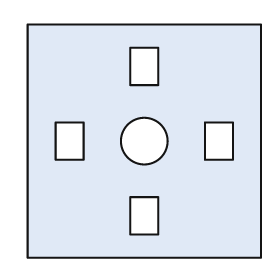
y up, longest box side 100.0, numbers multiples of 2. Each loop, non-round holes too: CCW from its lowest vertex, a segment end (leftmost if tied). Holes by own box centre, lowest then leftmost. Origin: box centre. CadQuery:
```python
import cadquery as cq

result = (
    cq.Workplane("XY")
    .moveTo(-50.0, -50.0)
    .lineTo(50.0, -50.0)
    .lineTo(50.0, 50.0)
    .lineTo(-50.0, 50.0)
    .close()
    .moveTo(-6.0, -40.0)
    .lineTo(6.0, -40.0)
    .lineTo(6.0, -24.0)
    .lineTo(-6.0, -24.0)
    .close()
    .moveTo(-38.0, -8.0)
    .lineTo(-26.0, -8.0)
    .lineTo(-26.0, 8.0)
    .lineTo(-38.0, 8.0)
    .close()
    .moveTo(0.0, 0.0)
    .circle(10.0)
    .moveTo(26.0, -8.0)
    .lineTo(38.0, -8.0)
    .lineTo(38.0, 8.0)
    .lineTo(26.0, 8.0)
    .close()
    .moveTo(-6.0, 24.0)
    .lineTo(6.0, 24.0)
    .lineTo(6.0, 40.0)
    .lineTo(-6.0, 40.0)
    .close()
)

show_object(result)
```